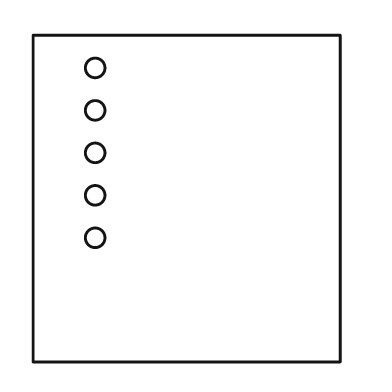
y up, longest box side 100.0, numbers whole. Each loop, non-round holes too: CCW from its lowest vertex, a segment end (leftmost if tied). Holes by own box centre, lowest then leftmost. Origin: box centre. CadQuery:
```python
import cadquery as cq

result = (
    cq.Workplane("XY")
    .moveTo(-47.0, -50.0)
    .lineTo(47.0, -50.0)
    .lineTo(47.0, 50.0)
    .lineTo(-47.0, 50.0)
    .close()
    .moveTo(-28.0, -12.0)
    .circle(3.0)
    .moveTo(-28.0, 1.0)
    .circle(3.0)
    .moveTo(-28.0, 14.0)
    .circle(3.0)
    .moveTo(-28.0, 27.0)
    .circle(3.0)
    .moveTo(-28.0, 40.0)
    .circle(3.0)
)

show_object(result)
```